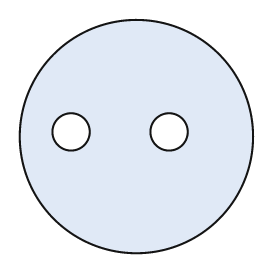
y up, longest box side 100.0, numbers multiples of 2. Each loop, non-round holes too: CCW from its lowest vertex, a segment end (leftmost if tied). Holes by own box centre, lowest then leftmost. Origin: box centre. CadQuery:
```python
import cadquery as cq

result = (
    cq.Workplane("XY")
    .moveTo(0.0, 0.0)
    .circle(50.0)
    .moveTo(-28.0, 2.0)
    .circle(8.0)
    .moveTo(14.0, 2.0)
    .circle(8.0)
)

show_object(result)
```